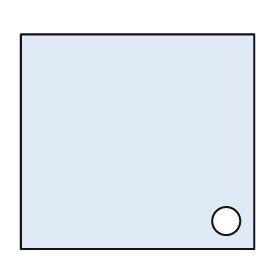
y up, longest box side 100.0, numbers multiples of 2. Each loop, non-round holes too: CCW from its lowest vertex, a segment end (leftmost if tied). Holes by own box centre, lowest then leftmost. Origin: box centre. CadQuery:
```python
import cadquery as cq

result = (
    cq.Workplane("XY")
    .moveTo(-50.0, -46.0)
    .lineTo(50.0, -46.0)
    .lineTo(50.0, 46.0)
    .lineTo(-50.0, 46.0)
    .close()
    .moveTo(38.0, -34.0)
    .circle(6.0)
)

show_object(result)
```